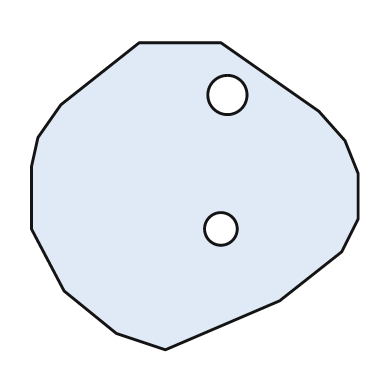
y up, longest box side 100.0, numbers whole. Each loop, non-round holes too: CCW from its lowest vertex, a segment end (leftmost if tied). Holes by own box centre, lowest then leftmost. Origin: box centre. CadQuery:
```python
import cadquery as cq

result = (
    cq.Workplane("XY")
    .moveTo(-9.0, -47.0)
    .lineTo(26.0, -32.0)
    .lineTo(45.0, -17.0)
    .lineTo(50.0, -7.0)
    .lineTo(50.0, 7.0)
    .lineTo(46.0, 17.0)
    .lineTo(38.0, 26.0)
    .lineTo(8.0, 47.0)
    .lineTo(-17.0, 47.0)
    .lineTo(-41.0, 28.0)
    .lineTo(-48.0, 18.0)
    .lineTo(-50.0, 9.0)
    .lineTo(-50.0, -10.0)
    .lineTo(-40.0, -29.0)
    .lineTo(-24.0, -42.0)
    .close()
    .moveTo(8.0, -10.0)
    .circle(5.0)
    .moveTo(10.0, 31.0)
    .circle(6.0)
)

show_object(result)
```